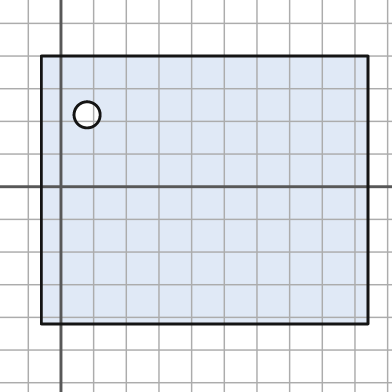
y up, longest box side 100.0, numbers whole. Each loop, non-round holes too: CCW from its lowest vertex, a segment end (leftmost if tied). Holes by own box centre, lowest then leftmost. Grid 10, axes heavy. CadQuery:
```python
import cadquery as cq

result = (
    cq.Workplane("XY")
    .moveTo(-6.0, -42.0)
    .lineTo(94.0, -42.0)
    .lineTo(94.0, 40.0)
    .lineTo(-6.0, 40.0)
    .close()
    .moveTo(8.0, 22.0)
    .circle(4.0)
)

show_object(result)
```